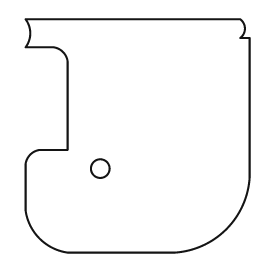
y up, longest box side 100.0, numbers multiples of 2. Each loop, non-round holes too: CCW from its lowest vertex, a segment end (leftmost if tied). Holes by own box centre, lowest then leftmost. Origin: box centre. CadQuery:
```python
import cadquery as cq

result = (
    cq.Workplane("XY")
    .moveTo(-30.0, -50.0)
    .lineTo(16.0, -50.0)
    .threePointArc((38.0, -40.0), (48.0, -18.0))
    .lineTo(48.0, 42.0)
    .lineTo(44.0, 42.0)
    .threePointArc((46.0, 46.0), (44.0, 50.0))
    .lineTo(-48.0, 50.0)
    .threePointArc((-46.0, 44.0), (-48.0, 38.0))
    .lineTo(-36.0, 38.0)
    .threePointArc((-32.0, 36.0), (-30.0, 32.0))
    .lineTo(-30.0, -6.0)
    .lineTo(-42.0, -6.0)
    .threePointArc((-46.0, -8.0), (-48.0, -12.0))
    .lineTo(-48.0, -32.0)
    .threePointArc((-42.0, -44.0), (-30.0, -50.0))
    .close()
    .moveTo(-16.0, -14.0)
    .circle(4.0)
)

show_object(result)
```